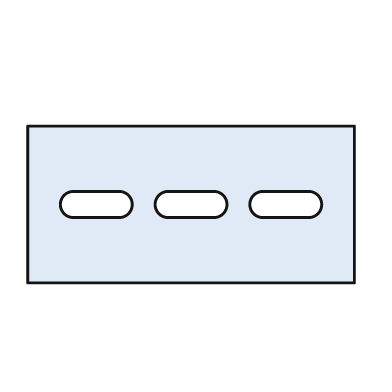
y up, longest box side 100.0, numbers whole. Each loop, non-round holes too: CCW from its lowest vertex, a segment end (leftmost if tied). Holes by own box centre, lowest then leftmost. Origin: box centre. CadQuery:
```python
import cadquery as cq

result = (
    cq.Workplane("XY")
    .moveTo(-50.0, -24.0)
    .lineTo(50.0, -24.0)
    .lineTo(50.0, 24.0)
    .lineTo(-50.0, 24.0)
    .close()
    .moveTo(-36.0, -4.0)
    .lineTo(-22.0, -4.0)
    .threePointArc((-18.0, 0.0), (-22.0, 4.0))
    .lineTo(-36.0, 4.0)
    .threePointArc((-40.0, 0.0), (-36.0, -4.0))
    .close()
    .moveTo(-7.0, -4.0)
    .lineTo(7.0, -4.0)
    .threePointArc((11.0, 0.0), (7.0, 4.0))
    .lineTo(-7.0, 4.0)
    .threePointArc((-11.0, 0.0), (-7.0, -4.0))
    .close()
    .moveTo(22.0, -4.0)
    .lineTo(36.0, -4.0)
    .threePointArc((40.0, 0.0), (36.0, 4.0))
    .lineTo(22.0, 4.0)
    .threePointArc((18.0, 0.0), (22.0, -4.0))
    .close()
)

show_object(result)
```